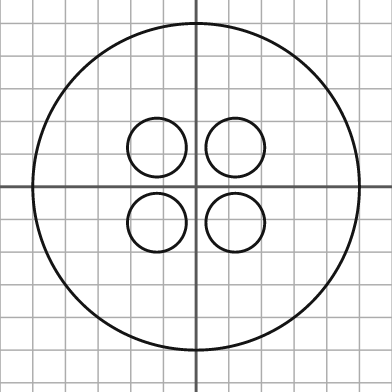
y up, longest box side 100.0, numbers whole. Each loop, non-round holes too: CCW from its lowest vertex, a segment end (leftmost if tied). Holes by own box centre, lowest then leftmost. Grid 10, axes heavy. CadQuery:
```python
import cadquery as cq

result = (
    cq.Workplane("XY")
    .moveTo(0.0, 0.0)
    .circle(50.0)
    .moveTo(-12.0, -11.0)
    .circle(9.0)
    .moveTo(12.0, -11.0)
    .circle(9.0)
    .moveTo(-12.0, 12.0)
    .circle(9.0)
    .moveTo(12.0, 12.0)
    .circle(9.0)
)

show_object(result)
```